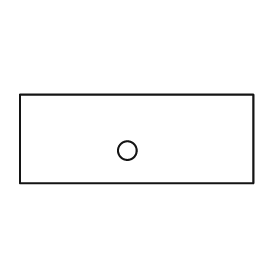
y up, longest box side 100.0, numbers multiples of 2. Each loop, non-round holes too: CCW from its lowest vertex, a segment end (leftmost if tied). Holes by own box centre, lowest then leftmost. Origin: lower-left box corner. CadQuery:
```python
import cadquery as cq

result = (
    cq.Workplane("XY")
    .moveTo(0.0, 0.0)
    .lineTo(100.0, 0.0)
    .lineTo(100.0, 38.0)
    .lineTo(0.0, 38.0)
    .close()
    .moveTo(46.0, 14.0)
    .circle(4.0)
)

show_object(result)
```